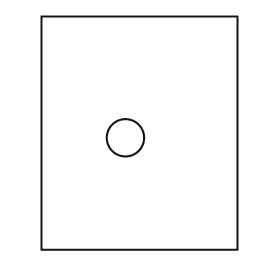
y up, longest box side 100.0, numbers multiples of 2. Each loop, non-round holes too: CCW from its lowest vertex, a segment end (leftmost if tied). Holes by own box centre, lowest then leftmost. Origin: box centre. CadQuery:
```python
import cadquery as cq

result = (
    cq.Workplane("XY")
    .moveTo(-42.0, -50.0)
    .lineTo(42.0, -50.0)
    .lineTo(42.0, 50.0)
    .lineTo(-42.0, 50.0)
    .close()
    .moveTo(-6.0, -2.0)
    .circle(8.0)
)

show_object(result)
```